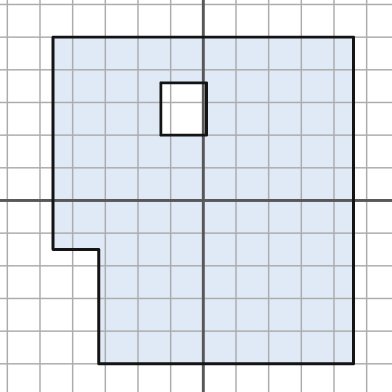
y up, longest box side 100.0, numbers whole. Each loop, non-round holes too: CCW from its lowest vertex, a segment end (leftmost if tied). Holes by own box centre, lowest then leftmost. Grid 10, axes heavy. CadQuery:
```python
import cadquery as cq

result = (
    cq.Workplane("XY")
    .moveTo(-32.0, -50.0)
    .lineTo(46.0, -50.0)
    .lineTo(46.0, 50.0)
    .lineTo(-46.0, 50.0)
    .lineTo(-46.0, -15.0)
    .lineTo(-32.0, -15.0)
    .close()
    .moveTo(-13.0, 20.0)
    .lineTo(1.0, 20.0)
    .lineTo(1.0, 36.0)
    .lineTo(-13.0, 36.0)
    .close()
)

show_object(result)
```